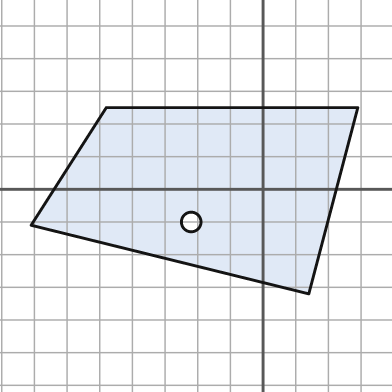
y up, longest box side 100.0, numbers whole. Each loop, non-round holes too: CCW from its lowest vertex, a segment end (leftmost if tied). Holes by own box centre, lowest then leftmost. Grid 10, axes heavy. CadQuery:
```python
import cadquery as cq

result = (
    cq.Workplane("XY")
    .moveTo(14.0, -32.0)
    .lineTo(29.0, 25.0)
    .lineTo(-48.0, 25.0)
    .lineTo(-71.0, -11.0)
    .close()
    .moveTo(-22.0, -10.0)
    .circle(3.0)
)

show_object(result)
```